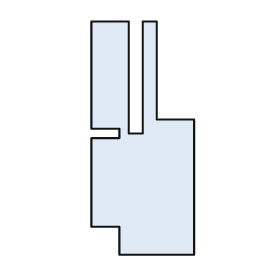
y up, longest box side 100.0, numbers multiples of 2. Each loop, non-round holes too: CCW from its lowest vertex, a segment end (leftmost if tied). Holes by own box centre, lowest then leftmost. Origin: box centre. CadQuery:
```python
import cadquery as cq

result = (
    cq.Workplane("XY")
    .moveTo(-10.0, -50.0)
    .lineTo(22.0, -50.0)
    .lineTo(22.0, 8.0)
    .lineTo(6.0, 8.0)
    .lineTo(6.0, 50.0)
    .lineTo(0.0, 50.0)
    .lineTo(0.0, 2.0)
    .lineTo(-6.0, 2.0)
    .lineTo(-6.0, 50.0)
    .lineTo(-22.0, 50.0)
    .lineTo(-22.0, 4.0)
    .lineTo(-10.0, 4.0)
    .lineTo(-10.0, 0.0)
    .lineTo(-22.0, 0.0)
    .lineTo(-22.0, -38.0)
    .lineTo(-10.0, -38.0)
    .close()
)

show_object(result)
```